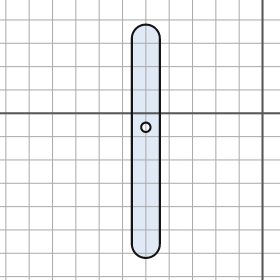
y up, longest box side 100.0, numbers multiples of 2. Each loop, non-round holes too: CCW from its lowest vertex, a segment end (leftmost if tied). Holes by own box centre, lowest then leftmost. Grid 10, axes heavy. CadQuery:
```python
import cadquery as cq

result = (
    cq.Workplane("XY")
    .moveTo(-56.0, -56.0)
    .threePointArc((-50.0, -62.0), (-44.0, -56.0))
    .lineTo(-44.0, 32.0)
    .threePointArc((-50.0, 38.0), (-56.0, 32.0))
    .close()
    .moveTo(-50.0, -6.0)
    .circle(2.0)
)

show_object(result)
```